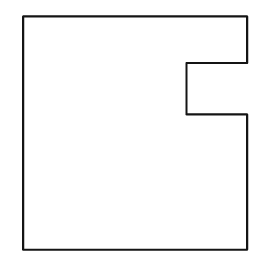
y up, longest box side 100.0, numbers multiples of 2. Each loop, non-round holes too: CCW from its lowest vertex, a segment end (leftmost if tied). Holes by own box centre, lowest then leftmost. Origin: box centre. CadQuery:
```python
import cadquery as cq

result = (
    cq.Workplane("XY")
    .moveTo(-48.0, -50.0)
    .lineTo(48.0, -50.0)
    .lineTo(48.0, 8.0)
    .lineTo(22.0, 8.0)
    .lineTo(22.0, 30.0)
    .lineTo(48.0, 30.0)
    .lineTo(48.0, 50.0)
    .lineTo(-48.0, 50.0)
    .close()
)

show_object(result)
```